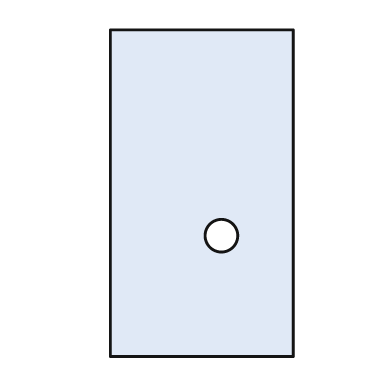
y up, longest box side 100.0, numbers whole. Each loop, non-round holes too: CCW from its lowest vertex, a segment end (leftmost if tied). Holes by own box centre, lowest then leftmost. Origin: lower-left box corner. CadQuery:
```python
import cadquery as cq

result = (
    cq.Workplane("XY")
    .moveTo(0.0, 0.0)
    .lineTo(56.0, 0.0)
    .lineTo(56.0, 100.0)
    .lineTo(0.0, 100.0)
    .close()
    .moveTo(34.0, 37.0)
    .circle(5.0)
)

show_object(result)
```